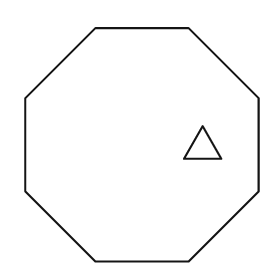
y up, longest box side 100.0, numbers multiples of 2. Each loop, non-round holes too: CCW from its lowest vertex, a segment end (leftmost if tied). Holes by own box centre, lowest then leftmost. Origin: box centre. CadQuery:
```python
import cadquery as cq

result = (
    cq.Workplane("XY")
    .moveTo(-20.0, -50.0)
    .lineTo(20.0, -50.0)
    .lineTo(50.0, -20.0)
    .lineTo(50.0, 20.0)
    .lineTo(20.0, 50.0)
    .lineTo(-20.0, 50.0)
    .lineTo(-50.0, 20.0)
    .lineTo(-50.0, -20.0)
    .close()
    .moveTo(18.0, -6.0)
    .lineTo(34.0, -6.0)
    .lineTo(26.0, 8.0)
    .close()
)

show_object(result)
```